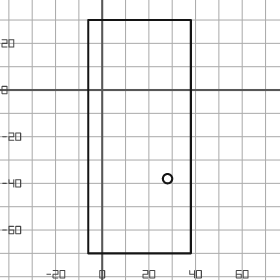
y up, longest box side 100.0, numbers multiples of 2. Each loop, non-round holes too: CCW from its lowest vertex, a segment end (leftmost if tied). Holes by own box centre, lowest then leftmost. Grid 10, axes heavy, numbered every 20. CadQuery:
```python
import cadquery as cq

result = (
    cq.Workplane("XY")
    .moveTo(-6.0, -70.0)
    .lineTo(38.0, -70.0)
    .lineTo(38.0, 30.0)
    .lineTo(-6.0, 30.0)
    .close()
    .moveTo(28.0, -38.0)
    .circle(2.0)
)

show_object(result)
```